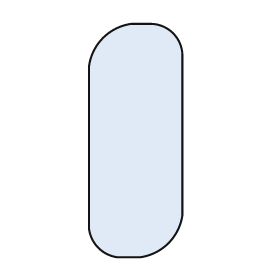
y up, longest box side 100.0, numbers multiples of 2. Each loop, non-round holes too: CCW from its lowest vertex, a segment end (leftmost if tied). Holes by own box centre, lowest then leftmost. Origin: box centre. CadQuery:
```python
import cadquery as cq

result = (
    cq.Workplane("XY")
    .moveTo(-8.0, -50.0)
    .lineTo(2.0, -50.0)
    .threePointArc((14.0, -44.0), (20.0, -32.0))
    .lineTo(20.0, 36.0)
    .threePointArc((16.0, 46.0), (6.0, 50.0))
    .lineTo(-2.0, 50.0)
    .threePointArc((-14.0, 44.0), (-20.0, 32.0))
    .lineTo(-20.0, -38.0)
    .threePointArc((-16.0, -46.0), (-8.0, -50.0))
    .close()
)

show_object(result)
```